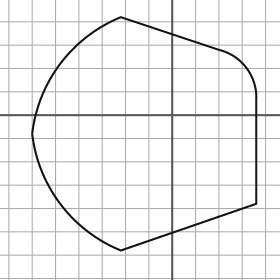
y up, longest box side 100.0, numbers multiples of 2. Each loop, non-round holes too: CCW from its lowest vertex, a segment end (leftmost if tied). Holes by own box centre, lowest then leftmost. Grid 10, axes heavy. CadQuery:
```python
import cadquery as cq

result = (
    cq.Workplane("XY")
    .moveTo(-22.0, -58.0)
    .lineTo(36.0, -38.0)
    .lineTo(36.0, 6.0)
    .threePointArc((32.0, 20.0), (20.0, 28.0))
    .lineTo(-22.0, 42.0)
    .threePointArc((-48.0, 22.0), (-60.0, -8.0))
    .threePointArc((-48.0, -38.0), (-22.0, -58.0))
    .close()
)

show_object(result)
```